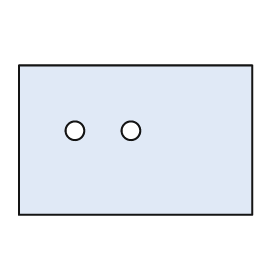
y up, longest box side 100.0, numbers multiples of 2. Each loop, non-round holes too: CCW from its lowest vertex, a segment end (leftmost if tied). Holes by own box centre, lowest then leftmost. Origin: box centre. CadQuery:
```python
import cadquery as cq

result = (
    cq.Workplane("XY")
    .moveTo(-50.0, -32.0)
    .lineTo(50.0, -32.0)
    .lineTo(50.0, 32.0)
    .lineTo(-50.0, 32.0)
    .close()
    .moveTo(-26.0, 4.0)
    .circle(4.0)
    .moveTo(-2.0, 4.0)
    .circle(4.0)
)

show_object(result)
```